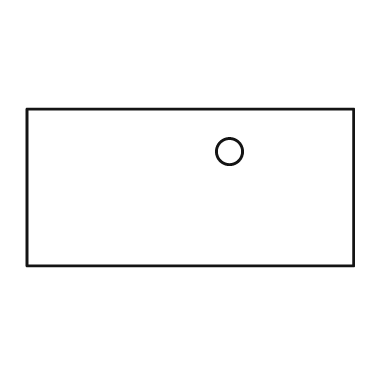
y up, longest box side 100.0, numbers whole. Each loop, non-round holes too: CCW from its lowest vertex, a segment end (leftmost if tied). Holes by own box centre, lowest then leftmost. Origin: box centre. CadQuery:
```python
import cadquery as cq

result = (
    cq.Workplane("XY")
    .moveTo(-50.0, -24.0)
    .lineTo(50.0, -24.0)
    .lineTo(50.0, 24.0)
    .lineTo(-50.0, 24.0)
    .close()
    .moveTo(12.0, 11.0)
    .circle(4.0)
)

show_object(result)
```